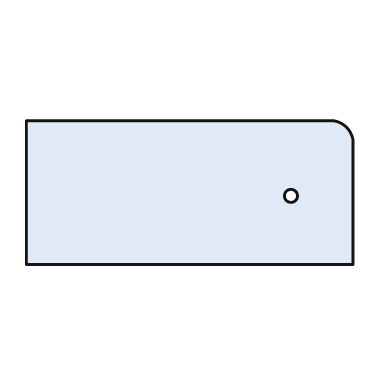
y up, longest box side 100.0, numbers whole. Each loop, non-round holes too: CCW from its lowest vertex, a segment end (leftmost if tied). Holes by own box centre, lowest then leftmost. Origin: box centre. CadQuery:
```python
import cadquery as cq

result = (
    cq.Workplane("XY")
    .moveTo(-50.0, -22.0)
    .lineTo(50.0, -22.0)
    .lineTo(50.0, 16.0)
    .threePointArc((48.0, 20.0), (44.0, 22.0))
    .lineTo(-50.0, 22.0)
    .close()
    .moveTo(31.0, -1.0)
    .circle(2.0)
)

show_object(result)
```